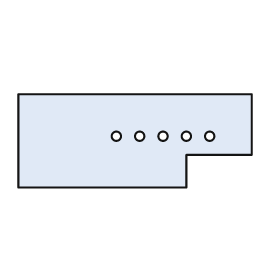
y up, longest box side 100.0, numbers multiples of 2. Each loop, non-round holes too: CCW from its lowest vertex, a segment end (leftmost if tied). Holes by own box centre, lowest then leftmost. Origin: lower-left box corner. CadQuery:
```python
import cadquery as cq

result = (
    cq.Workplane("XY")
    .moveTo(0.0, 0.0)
    .lineTo(72.0, 0.0)
    .lineTo(72.0, 14.0)
    .lineTo(100.0, 14.0)
    .lineTo(100.0, 40.0)
    .lineTo(0.0, 40.0)
    .close()
    .moveTo(42.0, 22.0)
    .circle(2.0)
    .moveTo(52.0, 22.0)
    .circle(2.0)
    .moveTo(62.0, 22.0)
    .circle(2.0)
    .moveTo(72.0, 22.0)
    .circle(2.0)
    .moveTo(82.0, 22.0)
    .circle(2.0)
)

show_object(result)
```